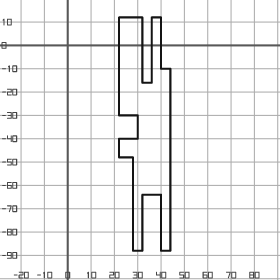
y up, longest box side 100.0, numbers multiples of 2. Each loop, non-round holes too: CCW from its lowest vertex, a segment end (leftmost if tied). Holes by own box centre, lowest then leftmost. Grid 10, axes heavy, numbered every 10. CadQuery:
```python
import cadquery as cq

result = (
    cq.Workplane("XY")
    .moveTo(28.0, -88.0)
    .lineTo(32.0, -88.0)
    .lineTo(32.0, -64.0)
    .lineTo(40.0, -64.0)
    .lineTo(40.0, -88.0)
    .lineTo(44.0, -88.0)
    .lineTo(44.0, -10.0)
    .lineTo(40.0, -10.0)
    .lineTo(40.0, 12.0)
    .lineTo(36.0, 12.0)
    .lineTo(36.0, -16.0)
    .lineTo(32.0, -16.0)
    .lineTo(32.0, 12.0)
    .lineTo(22.0, 12.0)
    .lineTo(22.0, -30.0)
    .lineTo(30.0, -30.0)
    .lineTo(30.0, -40.0)
    .lineTo(22.0, -40.0)
    .lineTo(22.0, -48.0)
    .lineTo(28.0, -48.0)
    .close()
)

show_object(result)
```